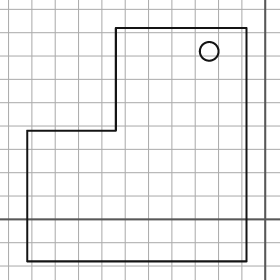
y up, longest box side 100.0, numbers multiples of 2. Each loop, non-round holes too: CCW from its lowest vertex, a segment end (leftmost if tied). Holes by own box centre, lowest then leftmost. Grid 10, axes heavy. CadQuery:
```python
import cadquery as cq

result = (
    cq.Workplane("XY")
    .moveTo(-102.0, -18.0)
    .lineTo(-8.0, -18.0)
    .lineTo(-8.0, 82.0)
    .lineTo(-64.0, 82.0)
    .lineTo(-64.0, 38.0)
    .lineTo(-102.0, 38.0)
    .close()
    .moveTo(-24.0, 72.0)
    .circle(4.0)
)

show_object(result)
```